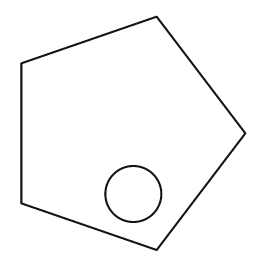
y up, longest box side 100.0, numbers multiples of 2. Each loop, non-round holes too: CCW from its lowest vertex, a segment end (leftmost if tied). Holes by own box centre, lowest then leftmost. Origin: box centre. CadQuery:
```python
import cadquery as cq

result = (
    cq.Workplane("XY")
    .moveTo(10.0, -50.0)
    .lineTo(48.0, 0.0)
    .lineTo(10.0, 50.0)
    .lineTo(-48.0, 30.0)
    .lineTo(-48.0, -30.0)
    .close()
    .moveTo(0.0, -26.0)
    .circle(12.0)
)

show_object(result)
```